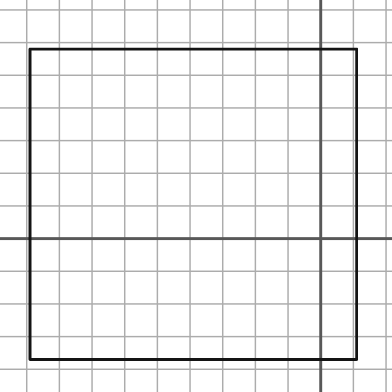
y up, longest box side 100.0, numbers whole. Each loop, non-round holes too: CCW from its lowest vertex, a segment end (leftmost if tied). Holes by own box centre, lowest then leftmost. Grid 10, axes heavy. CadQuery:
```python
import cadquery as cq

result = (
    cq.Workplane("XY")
    .moveTo(-89.0, -37.0)
    .lineTo(11.0, -37.0)
    .lineTo(11.0, 58.0)
    .lineTo(-89.0, 58.0)
    .close()
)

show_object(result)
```